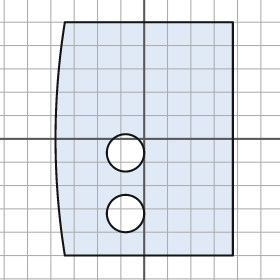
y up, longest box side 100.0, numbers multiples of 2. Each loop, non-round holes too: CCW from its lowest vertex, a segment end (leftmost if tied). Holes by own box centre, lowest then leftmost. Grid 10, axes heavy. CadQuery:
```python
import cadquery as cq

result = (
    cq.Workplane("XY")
    .moveTo(-34.0, -50.0)
    .lineTo(38.0, -50.0)
    .lineTo(38.0, 50.0)
    .lineTo(-34.0, 50.0)
    .threePointArc((-38.0, 0.0), (-34.0, -50.0))
    .close()
    .moveTo(-8.0, -32.0)
    .circle(8.0)
    .moveTo(-8.0, -6.0)
    .circle(8.0)
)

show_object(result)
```